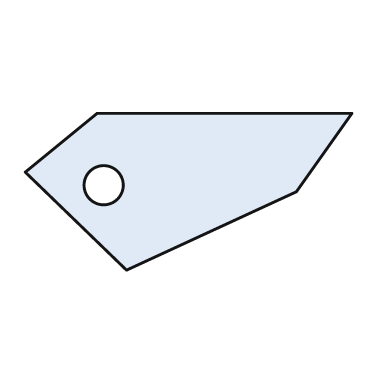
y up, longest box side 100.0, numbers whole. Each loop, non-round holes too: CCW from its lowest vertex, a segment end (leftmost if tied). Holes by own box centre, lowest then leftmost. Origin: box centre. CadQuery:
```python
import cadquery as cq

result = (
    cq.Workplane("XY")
    .moveTo(-19.0, -24.0)
    .lineTo(33.0, 0.0)
    .lineTo(50.0, 24.0)
    .lineTo(-28.0, 24.0)
    .lineTo(-50.0, 6.0)
    .close()
    .moveTo(-26.0, 2.0)
    .circle(6.0)
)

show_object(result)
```